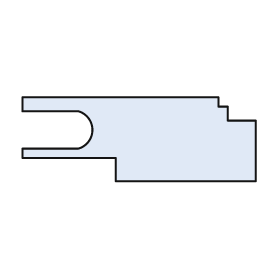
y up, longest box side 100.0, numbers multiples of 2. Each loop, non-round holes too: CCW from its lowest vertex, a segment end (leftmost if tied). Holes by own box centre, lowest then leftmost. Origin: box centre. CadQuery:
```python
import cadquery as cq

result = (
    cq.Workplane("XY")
    .moveTo(-10.0, -18.0)
    .lineTo(50.0, -18.0)
    .lineTo(50.0, 8.0)
    .lineTo(38.0, 8.0)
    .lineTo(38.0, 14.0)
    .lineTo(34.0, 14.0)
    .lineTo(34.0, 18.0)
    .lineTo(-50.0, 18.0)
    .lineTo(-50.0, 12.0)
    .lineTo(-26.0, 12.0)
    .threePointArc((-20.0, 4.0), (-26.0, -4.0))
    .lineTo(-50.0, -4.0)
    .lineTo(-50.0, -8.0)
    .lineTo(-10.0, -8.0)
    .close()
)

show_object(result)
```